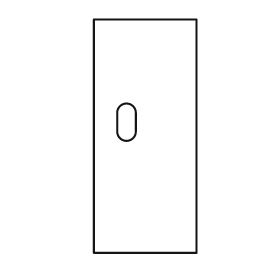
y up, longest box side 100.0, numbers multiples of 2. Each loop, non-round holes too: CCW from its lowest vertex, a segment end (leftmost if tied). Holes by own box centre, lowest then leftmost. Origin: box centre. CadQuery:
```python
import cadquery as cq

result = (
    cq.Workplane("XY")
    .moveTo(-22.0, -50.0)
    .lineTo(22.0, -50.0)
    .lineTo(22.0, 50.0)
    .lineTo(-22.0, 50.0)
    .close()
    .moveTo(-12.0, 2.0)
    .threePointArc((-8.0, -2.0), (-4.0, 2.0))
    .lineTo(-4.0, 10.0)
    .threePointArc((-8.0, 14.0), (-12.0, 10.0))
    .close()
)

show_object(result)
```